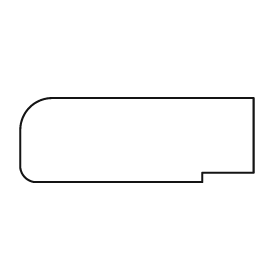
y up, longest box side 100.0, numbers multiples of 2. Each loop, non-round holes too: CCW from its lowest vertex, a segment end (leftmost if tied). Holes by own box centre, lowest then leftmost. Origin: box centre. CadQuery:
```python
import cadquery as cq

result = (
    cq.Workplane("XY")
    .moveTo(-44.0, -18.0)
    .lineTo(28.0, -18.0)
    .lineTo(28.0, -14.0)
    .lineTo(50.0, -14.0)
    .lineTo(50.0, 18.0)
    .lineTo(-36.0, 18.0)
    .threePointArc((-46.0, 14.0), (-50.0, 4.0))
    .lineTo(-50.0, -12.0)
    .threePointArc((-48.0, -16.0), (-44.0, -18.0))
    .close()
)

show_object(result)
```